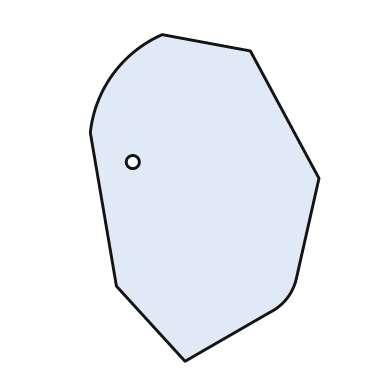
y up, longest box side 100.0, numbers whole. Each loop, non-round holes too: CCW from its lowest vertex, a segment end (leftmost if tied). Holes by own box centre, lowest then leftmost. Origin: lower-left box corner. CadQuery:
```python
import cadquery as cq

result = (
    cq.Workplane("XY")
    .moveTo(29.0, 0.0)
    .lineTo(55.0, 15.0)
    .threePointArc((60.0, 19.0), (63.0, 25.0))
    .lineTo(70.0, 56.0)
    .lineTo(49.0, 95.0)
    .lineTo(22.0, 100.0)
    .threePointArc((7.0, 88.0), (0.0, 70.0))
    .lineTo(8.0, 23.0)
    .close()
    .moveTo(13.0, 61.0)
    .circle(2.0)
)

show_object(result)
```